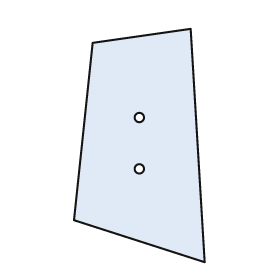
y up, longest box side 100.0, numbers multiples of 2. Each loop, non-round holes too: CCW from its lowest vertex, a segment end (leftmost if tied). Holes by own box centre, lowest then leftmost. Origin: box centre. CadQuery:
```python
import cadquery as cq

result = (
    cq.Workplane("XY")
    .moveTo(28.0, -50.0)
    .lineTo(22.0, 50.0)
    .lineTo(-20.0, 44.0)
    .lineTo(-28.0, -32.0)
    .close()
    .moveTo(0.0, -10.0)
    .circle(2.0)
    .moveTo(0.0, 12.0)
    .circle(2.0)
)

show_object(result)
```